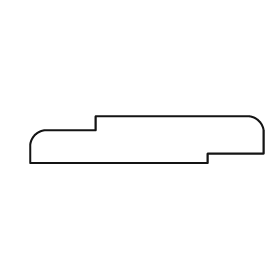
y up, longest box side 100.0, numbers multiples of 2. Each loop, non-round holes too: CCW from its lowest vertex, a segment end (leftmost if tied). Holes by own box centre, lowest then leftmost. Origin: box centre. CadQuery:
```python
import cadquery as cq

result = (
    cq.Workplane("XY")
    .moveTo(-50.0, -10.0)
    .lineTo(26.0, -10.0)
    .lineTo(26.0, -6.0)
    .lineTo(50.0, -6.0)
    .lineTo(50.0, 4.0)
    .threePointArc((48.0, 8.0), (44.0, 10.0))
    .lineTo(-22.0, 10.0)
    .lineTo(-22.0, 4.0)
    .lineTo(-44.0, 4.0)
    .threePointArc((-48.0, 2.0), (-50.0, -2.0))
    .close()
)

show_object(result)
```